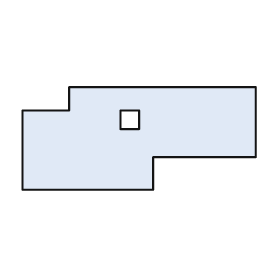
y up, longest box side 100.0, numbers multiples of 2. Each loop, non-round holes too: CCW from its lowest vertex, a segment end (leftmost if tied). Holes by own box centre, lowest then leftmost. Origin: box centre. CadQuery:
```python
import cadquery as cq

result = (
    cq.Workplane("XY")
    .moveTo(-50.0, -22.0)
    .lineTo(6.0, -22.0)
    .lineTo(6.0, -8.0)
    .lineTo(50.0, -8.0)
    .lineTo(50.0, 22.0)
    .lineTo(-30.0, 22.0)
    .lineTo(-30.0, 12.0)
    .lineTo(-50.0, 12.0)
    .close()
    .moveTo(-8.0, 4.0)
    .lineTo(0.0, 4.0)
    .lineTo(0.0, 12.0)
    .lineTo(-8.0, 12.0)
    .close()
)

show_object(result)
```